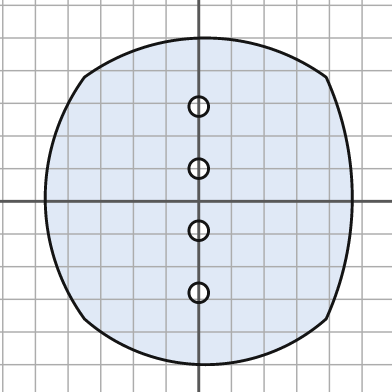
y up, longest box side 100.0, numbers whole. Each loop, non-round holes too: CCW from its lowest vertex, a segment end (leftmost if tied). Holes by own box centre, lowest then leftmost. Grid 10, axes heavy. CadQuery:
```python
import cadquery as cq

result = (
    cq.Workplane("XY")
    .moveTo(-35.0, -36.0)
    .threePointArc((2.0, -50.0), (39.0, -36.0))
    .threePointArc((47.0, 1.0), (39.0, 38.0))
    .threePointArc((2.0, 50.0), (-35.0, 38.0))
    .threePointArc((-47.0, 1.0), (-35.0, -36.0))
    .close()
    .moveTo(0.0, -28.0)
    .circle(3.0)
    .moveTo(0.0, -9.0)
    .circle(3.0)
    .moveTo(0.0, 10.0)
    .circle(3.0)
    .moveTo(0.0, 29.0)
    .circle(3.0)
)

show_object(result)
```